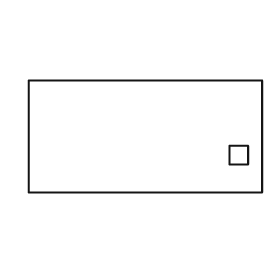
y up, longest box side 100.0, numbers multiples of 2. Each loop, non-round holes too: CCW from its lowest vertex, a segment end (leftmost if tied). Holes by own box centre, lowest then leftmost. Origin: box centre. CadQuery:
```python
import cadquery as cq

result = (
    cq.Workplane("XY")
    .moveTo(-50.0, -24.0)
    .lineTo(50.0, -24.0)
    .lineTo(50.0, 24.0)
    .lineTo(-50.0, 24.0)
    .close()
    .moveTo(36.0, -12.0)
    .lineTo(44.0, -12.0)
    .lineTo(44.0, -4.0)
    .lineTo(36.0, -4.0)
    .close()
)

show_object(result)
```